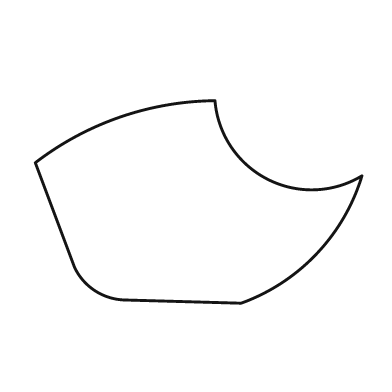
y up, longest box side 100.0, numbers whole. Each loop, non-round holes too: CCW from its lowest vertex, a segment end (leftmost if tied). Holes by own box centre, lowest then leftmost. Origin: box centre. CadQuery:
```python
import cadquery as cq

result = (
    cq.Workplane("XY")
    .moveTo(13.0, -31.0)
    .threePointArc((36.0, -16.0), (50.0, 8.0))
    .threePointArc((21.0, 7.0), (5.0, 31.0))
    .threePointArc((-24.0, 26.0), (-50.0, 12.0))
    .lineTo(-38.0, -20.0)
    .threePointArc((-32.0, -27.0), (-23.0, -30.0))
    .close()
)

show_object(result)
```